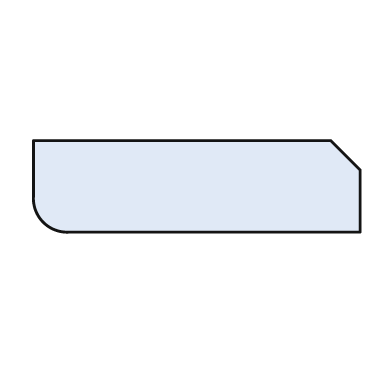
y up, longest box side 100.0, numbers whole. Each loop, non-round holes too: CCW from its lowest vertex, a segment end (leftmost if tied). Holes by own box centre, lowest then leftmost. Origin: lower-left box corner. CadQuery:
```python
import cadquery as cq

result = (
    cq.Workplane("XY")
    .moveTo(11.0, 0.0)
    .lineTo(100.0, 0.0)
    .lineTo(100.0, 19.0)
    .lineTo(91.0, 28.0)
    .lineTo(0.0, 28.0)
    .lineTo(0.0, 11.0)
    .threePointArc((3.0, 3.0), (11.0, 0.0))
    .close()
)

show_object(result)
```